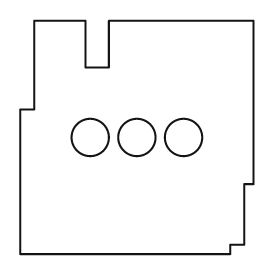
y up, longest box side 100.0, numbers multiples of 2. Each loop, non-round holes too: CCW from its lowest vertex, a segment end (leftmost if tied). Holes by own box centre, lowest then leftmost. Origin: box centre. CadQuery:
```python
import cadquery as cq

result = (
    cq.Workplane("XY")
    .moveTo(-50.0, -50.0)
    .lineTo(40.0, -50.0)
    .lineTo(40.0, -46.0)
    .lineTo(46.0, -46.0)
    .lineTo(46.0, -20.0)
    .lineTo(50.0, -20.0)
    .lineTo(50.0, 50.0)
    .lineTo(-12.0, 50.0)
    .lineTo(-12.0, 30.0)
    .lineTo(-22.0, 30.0)
    .lineTo(-22.0, 50.0)
    .lineTo(-44.0, 50.0)
    .lineTo(-44.0, 12.0)
    .lineTo(-50.0, 12.0)
    .close()
    .moveTo(-20.0, 0.0)
    .circle(8.0)
    .moveTo(0.0, 0.0)
    .circle(8.0)
    .moveTo(20.0, 0.0)
    .circle(8.0)
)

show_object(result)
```